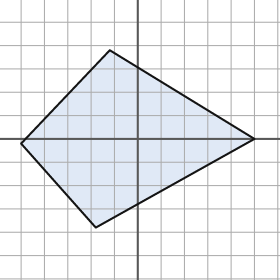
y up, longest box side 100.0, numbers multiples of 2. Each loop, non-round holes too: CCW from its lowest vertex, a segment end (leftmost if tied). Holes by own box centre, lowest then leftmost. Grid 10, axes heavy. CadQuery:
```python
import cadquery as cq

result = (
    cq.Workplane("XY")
    .moveTo(-18.0, -38.0)
    .lineTo(50.0, 0.0)
    .lineTo(-12.0, 38.0)
    .lineTo(-50.0, -2.0)
    .close()
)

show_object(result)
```